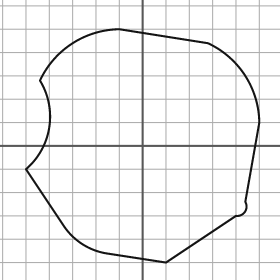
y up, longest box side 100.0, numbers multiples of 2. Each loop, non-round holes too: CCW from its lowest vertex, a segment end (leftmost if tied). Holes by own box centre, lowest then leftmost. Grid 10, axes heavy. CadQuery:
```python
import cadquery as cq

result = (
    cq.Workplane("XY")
    .moveTo(10.0, -50.0)
    .lineTo(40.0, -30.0)
    .threePointArc((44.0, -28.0), (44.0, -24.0))
    .lineTo(50.0, 10.0)
    .threePointArc((44.0, 30.0), (28.0, 44.0))
    .lineTo(-10.0, 50.0)
    .threePointArc((-30.0, 44.0), (-44.0, 28.0))
    .threePointArc((-40.0, 8.0), (-50.0, -10.0))
    .lineTo(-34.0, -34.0)
    .threePointArc((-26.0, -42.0), (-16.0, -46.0))
    .close()
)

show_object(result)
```